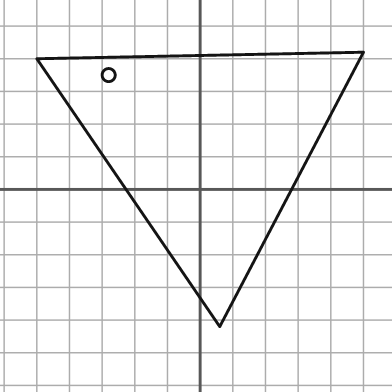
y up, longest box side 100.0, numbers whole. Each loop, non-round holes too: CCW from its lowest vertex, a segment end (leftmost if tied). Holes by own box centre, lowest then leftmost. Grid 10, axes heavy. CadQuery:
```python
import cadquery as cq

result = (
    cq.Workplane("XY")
    .moveTo(6.0, -42.0)
    .lineTo(50.0, 42.0)
    .lineTo(-50.0, 40.0)
    .close()
    .moveTo(-28.0, 35.0)
    .circle(2.0)
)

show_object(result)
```